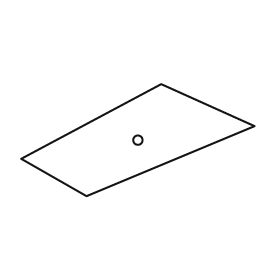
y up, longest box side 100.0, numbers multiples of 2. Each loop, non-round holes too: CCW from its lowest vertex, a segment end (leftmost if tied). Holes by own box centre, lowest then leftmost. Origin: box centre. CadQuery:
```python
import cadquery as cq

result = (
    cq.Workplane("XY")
    .moveTo(-22.0, -24.0)
    .lineTo(50.0, 6.0)
    .lineTo(10.0, 24.0)
    .lineTo(-50.0, -8.0)
    .close()
    .moveTo(0.0, 0.0)
    .circle(2.0)
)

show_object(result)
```